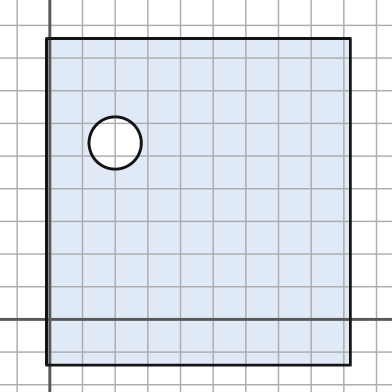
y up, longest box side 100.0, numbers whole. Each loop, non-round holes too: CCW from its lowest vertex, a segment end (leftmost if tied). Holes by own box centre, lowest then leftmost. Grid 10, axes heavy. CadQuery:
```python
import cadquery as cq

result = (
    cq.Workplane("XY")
    .moveTo(-1.0, -14.0)
    .lineTo(92.0, -14.0)
    .lineTo(92.0, 86.0)
    .lineTo(-1.0, 86.0)
    .close()
    .moveTo(20.0, 54.0)
    .circle(8.0)
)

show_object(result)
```